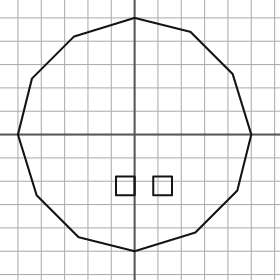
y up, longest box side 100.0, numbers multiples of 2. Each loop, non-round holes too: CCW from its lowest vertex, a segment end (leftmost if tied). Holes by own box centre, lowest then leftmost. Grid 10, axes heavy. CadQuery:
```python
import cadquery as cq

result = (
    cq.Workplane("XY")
    .moveTo(0.0, -50.0)
    .lineTo(26.0, -42.0)
    .lineTo(44.0, -24.0)
    .lineTo(50.0, 0.0)
    .lineTo(42.0, 26.0)
    .lineTo(24.0, 44.0)
    .lineTo(0.0, 50.0)
    .lineTo(-26.0, 42.0)
    .lineTo(-44.0, 24.0)
    .lineTo(-50.0, 0.0)
    .lineTo(-42.0, -26.0)
    .lineTo(-24.0, -44.0)
    .close()
    .moveTo(-8.0, -26.0)
    .lineTo(0.0, -26.0)
    .lineTo(0.0, -18.0)
    .lineTo(-8.0, -18.0)
    .close()
    .moveTo(8.0, -26.0)
    .lineTo(16.0, -26.0)
    .lineTo(16.0, -18.0)
    .lineTo(8.0, -18.0)
    .close()
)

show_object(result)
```